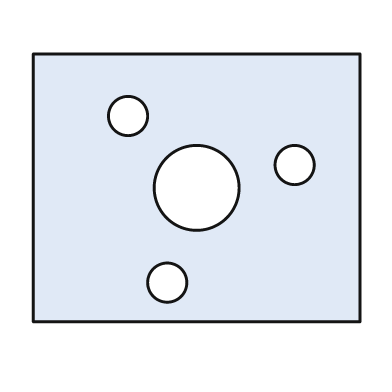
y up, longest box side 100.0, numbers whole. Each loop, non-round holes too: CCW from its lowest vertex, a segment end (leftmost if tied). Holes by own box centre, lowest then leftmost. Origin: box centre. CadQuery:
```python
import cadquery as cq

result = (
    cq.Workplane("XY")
    .moveTo(-50.0, -41.0)
    .lineTo(50.0, -41.0)
    .lineTo(50.0, 41.0)
    .lineTo(-50.0, 41.0)
    .close()
    .moveTo(-9.0, -29.0)
    .circle(6.0)
    .moveTo(0.0, 0.0)
    .circle(13.0)
    .moveTo(30.0, 7.0)
    .circle(6.0)
    .moveTo(-21.0, 22.0)
    .circle(6.0)
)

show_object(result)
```